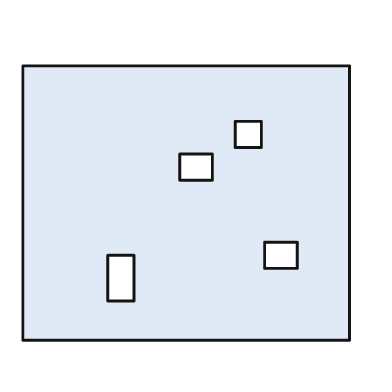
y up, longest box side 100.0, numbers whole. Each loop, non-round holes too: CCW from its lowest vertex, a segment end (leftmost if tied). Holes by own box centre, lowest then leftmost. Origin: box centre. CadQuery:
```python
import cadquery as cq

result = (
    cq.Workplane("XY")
    .moveTo(-50.0, -42.0)
    .lineTo(50.0, -42.0)
    .lineTo(50.0, 42.0)
    .lineTo(-50.0, 42.0)
    .close()
    .moveTo(-24.0, -30.0)
    .lineTo(-16.0, -30.0)
    .lineTo(-16.0, -16.0)
    .lineTo(-24.0, -16.0)
    .close()
    .moveTo(24.0, -20.0)
    .lineTo(34.0, -20.0)
    .lineTo(34.0, -12.0)
    .lineTo(24.0, -12.0)
    .close()
    .moveTo(-2.0, 7.0)
    .lineTo(8.0, 7.0)
    .lineTo(8.0, 15.0)
    .lineTo(-2.0, 15.0)
    .close()
    .moveTo(15.0, 17.0)
    .lineTo(23.0, 17.0)
    .lineTo(23.0, 25.0)
    .lineTo(15.0, 25.0)
    .close()
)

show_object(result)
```